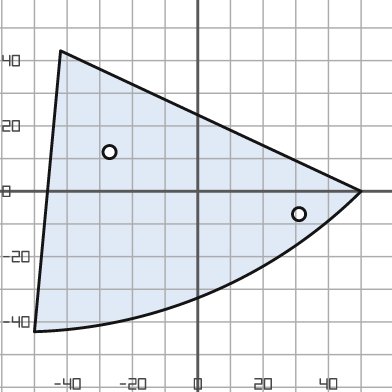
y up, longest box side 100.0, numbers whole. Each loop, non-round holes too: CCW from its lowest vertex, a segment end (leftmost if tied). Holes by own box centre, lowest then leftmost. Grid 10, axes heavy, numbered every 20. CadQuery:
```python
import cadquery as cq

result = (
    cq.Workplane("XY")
    .moveTo(-50.0, -43.0)
    .threePointArc((4.0, -31.0), (50.0, 0.0))
    .lineTo(-42.0, 43.0)
    .close()
    .moveTo(31.0, -7.0)
    .circle(2.0)
    .moveTo(-27.0, 12.0)
    .circle(2.0)
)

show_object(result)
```